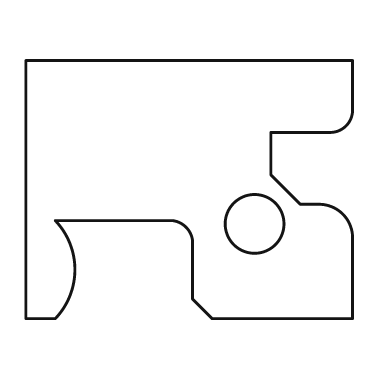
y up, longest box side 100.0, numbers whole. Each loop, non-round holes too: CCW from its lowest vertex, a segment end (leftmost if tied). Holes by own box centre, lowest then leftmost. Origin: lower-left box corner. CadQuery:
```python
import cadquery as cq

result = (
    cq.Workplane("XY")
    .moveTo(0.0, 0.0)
    .lineTo(9.0, 0.0)
    .threePointArc((15.0, 15.0), (9.0, 30.0))
    .lineTo(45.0, 30.0)
    .threePointArc((49.0, 28.0), (51.0, 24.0))
    .lineTo(51.0, 6.0)
    .lineTo(57.0, 0.0)
    .lineTo(100.0, 0.0)
    .lineTo(100.0, 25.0)
    .threePointArc((97.0, 32.0), (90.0, 35.0))
    .lineTo(84.0, 35.0)
    .lineTo(75.0, 44.0)
    .lineTo(75.0, 57.0)
    .lineTo(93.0, 57.0)
    .threePointArc((98.0, 59.0), (100.0, 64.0))
    .lineTo(100.0, 79.0)
    .lineTo(0.0, 79.0)
    .close()
    .moveTo(70.0, 29.0)
    .circle(9.0)
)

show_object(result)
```